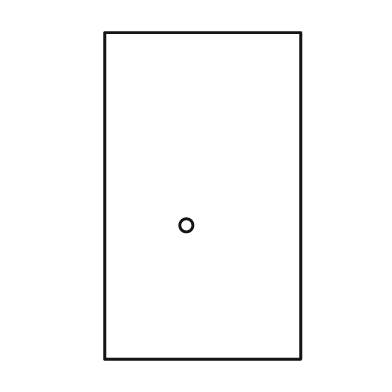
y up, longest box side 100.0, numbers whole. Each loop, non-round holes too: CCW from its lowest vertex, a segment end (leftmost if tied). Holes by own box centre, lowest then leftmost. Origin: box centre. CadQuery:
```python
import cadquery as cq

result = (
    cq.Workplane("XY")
    .moveTo(-30.0, -50.0)
    .lineTo(30.0, -50.0)
    .lineTo(30.0, 50.0)
    .lineTo(-30.0, 50.0)
    .close()
    .moveTo(-5.0, -9.0)
    .circle(2.0)
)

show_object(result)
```